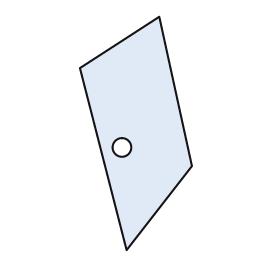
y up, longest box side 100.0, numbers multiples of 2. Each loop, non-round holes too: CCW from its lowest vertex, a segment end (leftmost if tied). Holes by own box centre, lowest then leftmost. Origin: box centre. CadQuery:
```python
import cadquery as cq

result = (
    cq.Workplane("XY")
    .moveTo(-4.0, -50.0)
    .lineTo(24.0, -14.0)
    .lineTo(10.0, 50.0)
    .lineTo(-24.0, 28.0)
    .close()
    .moveTo(-6.0, -6.0)
    .circle(4.0)
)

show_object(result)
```